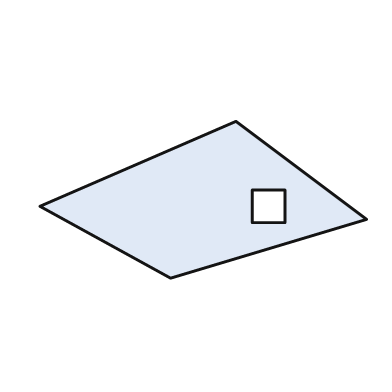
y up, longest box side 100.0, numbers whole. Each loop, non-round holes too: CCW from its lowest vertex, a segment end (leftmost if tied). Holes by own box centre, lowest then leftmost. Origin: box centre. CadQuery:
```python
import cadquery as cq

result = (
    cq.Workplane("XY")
    .moveTo(-10.0, -24.0)
    .lineTo(50.0, -6.0)
    .lineTo(10.0, 24.0)
    .lineTo(-50.0, -2.0)
    .close()
    .moveTo(15.0, -7.0)
    .lineTo(25.0, -7.0)
    .lineTo(25.0, 3.0)
    .lineTo(15.0, 3.0)
    .close()
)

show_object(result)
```